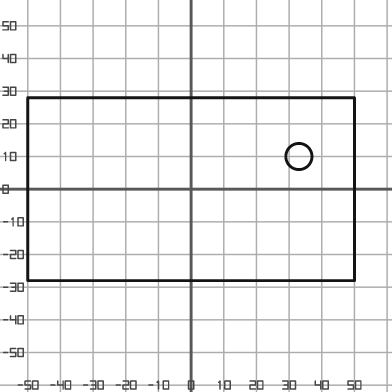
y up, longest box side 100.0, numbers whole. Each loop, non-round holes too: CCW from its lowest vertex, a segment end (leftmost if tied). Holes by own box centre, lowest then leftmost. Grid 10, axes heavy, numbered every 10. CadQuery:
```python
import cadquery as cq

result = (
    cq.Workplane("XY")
    .moveTo(-50.0, -28.0)
    .lineTo(50.0, -28.0)
    .lineTo(50.0, 28.0)
    .lineTo(-50.0, 28.0)
    .close()
    .moveTo(33.0, 10.0)
    .circle(4.0)
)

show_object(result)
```